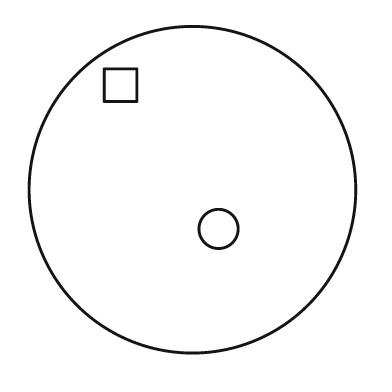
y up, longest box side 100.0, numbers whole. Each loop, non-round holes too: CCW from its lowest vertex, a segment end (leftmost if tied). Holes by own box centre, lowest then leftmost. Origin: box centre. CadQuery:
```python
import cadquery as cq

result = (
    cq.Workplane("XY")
    .moveTo(0.0, 0.0)
    .circle(50.0)
    .moveTo(8.0, -12.0)
    .circle(6.0)
    .moveTo(-27.0, 27.0)
    .lineTo(-17.0, 27.0)
    .lineTo(-17.0, 37.0)
    .lineTo(-27.0, 37.0)
    .close()
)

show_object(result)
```